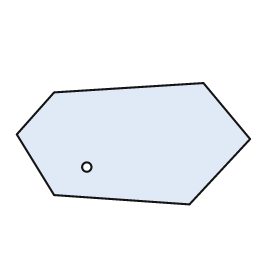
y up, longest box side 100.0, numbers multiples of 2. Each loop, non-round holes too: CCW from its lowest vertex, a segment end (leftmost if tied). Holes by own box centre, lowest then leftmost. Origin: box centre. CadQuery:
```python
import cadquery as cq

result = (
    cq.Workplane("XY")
    .moveTo(24.0, -26.0)
    .lineTo(50.0, 2.0)
    .lineTo(30.0, 26.0)
    .lineTo(-34.0, 22.0)
    .lineTo(-50.0, 4.0)
    .lineTo(-34.0, -22.0)
    .close()
    .moveTo(-20.0, -10.0)
    .circle(2.0)
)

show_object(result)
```